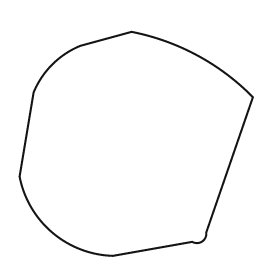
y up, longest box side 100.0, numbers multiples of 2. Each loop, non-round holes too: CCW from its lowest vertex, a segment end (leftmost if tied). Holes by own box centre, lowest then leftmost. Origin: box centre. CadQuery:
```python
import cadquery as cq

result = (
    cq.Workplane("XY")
    .moveTo(-10.0, -48.0)
    .lineTo(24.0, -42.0)
    .threePointArc((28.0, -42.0), (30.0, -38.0))
    .lineTo(50.0, 20.0)
    .threePointArc((26.0, 38.0), (-2.0, 48.0))
    .lineTo(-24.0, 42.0)
    .threePointArc((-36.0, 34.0), (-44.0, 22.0))
    .lineTo(-50.0, -14.0)
    .threePointArc((-36.0, -38.0), (-10.0, -48.0))
    .close()
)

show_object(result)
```